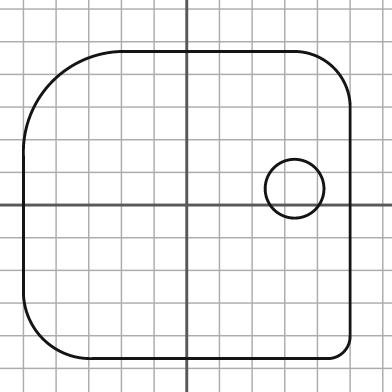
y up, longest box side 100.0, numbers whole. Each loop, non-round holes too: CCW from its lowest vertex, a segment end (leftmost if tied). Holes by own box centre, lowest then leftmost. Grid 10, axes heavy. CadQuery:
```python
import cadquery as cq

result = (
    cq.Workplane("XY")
    .moveTo(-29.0, -47.0)
    .lineTo(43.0, -47.0)
    .threePointArc((48.0, -45.0), (50.0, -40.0))
    .lineTo(50.0, 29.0)
    .threePointArc((45.0, 42.0), (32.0, 47.0))
    .lineTo(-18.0, 47.0)
    .threePointArc((-41.0, 38.0), (-50.0, 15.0))
    .lineTo(-50.0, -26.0)
    .threePointArc((-44.0, -41.0), (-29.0, -47.0))
    .close()
    .moveTo(33.0, 5.0)
    .circle(9.0)
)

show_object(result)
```